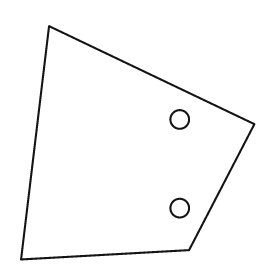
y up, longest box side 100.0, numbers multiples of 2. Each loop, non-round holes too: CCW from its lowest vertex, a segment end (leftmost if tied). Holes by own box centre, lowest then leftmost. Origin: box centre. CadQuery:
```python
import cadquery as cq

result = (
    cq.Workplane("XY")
    .moveTo(-50.0, -50.0)
    .lineTo(22.0, -46.0)
    .lineTo(50.0, 8.0)
    .lineTo(-38.0, 50.0)
    .close()
    .moveTo(18.0, -28.0)
    .circle(4.0)
    .moveTo(18.0, 10.0)
    .circle(4.0)
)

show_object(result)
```